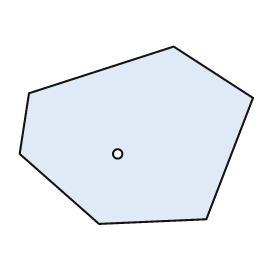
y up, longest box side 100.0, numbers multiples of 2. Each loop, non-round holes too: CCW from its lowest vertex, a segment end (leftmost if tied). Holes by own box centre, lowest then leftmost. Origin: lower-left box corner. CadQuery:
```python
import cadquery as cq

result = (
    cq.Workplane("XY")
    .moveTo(34.0, 0.0)
    .lineTo(80.0, 2.0)
    .lineTo(100.0, 54.0)
    .lineTo(66.0, 76.0)
    .lineTo(4.0, 56.0)
    .lineTo(0.0, 30.0)
    .close()
    .moveTo(42.0, 30.0)
    .circle(2.0)
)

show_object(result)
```